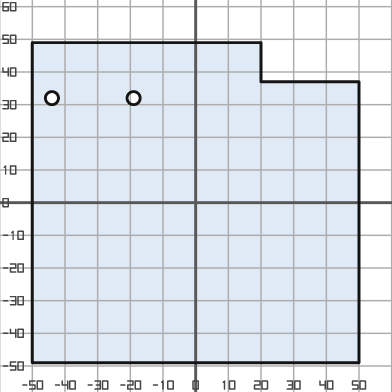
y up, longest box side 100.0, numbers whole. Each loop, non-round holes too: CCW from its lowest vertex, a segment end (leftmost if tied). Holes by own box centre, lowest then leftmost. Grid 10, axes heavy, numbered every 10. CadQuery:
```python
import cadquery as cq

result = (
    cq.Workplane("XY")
    .moveTo(-50.0, -49.0)
    .lineTo(50.0, -49.0)
    .lineTo(50.0, 37.0)
    .lineTo(20.0, 37.0)
    .lineTo(20.0, 49.0)
    .lineTo(-50.0, 49.0)
    .close()
    .moveTo(-44.0, 32.0)
    .circle(2.0)
    .moveTo(-19.0, 32.0)
    .circle(2.0)
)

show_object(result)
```